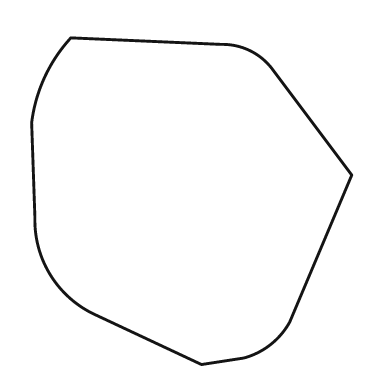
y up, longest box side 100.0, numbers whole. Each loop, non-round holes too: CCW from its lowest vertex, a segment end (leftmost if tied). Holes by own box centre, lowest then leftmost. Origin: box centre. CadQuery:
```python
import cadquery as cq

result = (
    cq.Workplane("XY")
    .moveTo(3.0, -50.0)
    .lineTo(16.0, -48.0)
    .threePointArc((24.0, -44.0), (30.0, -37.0))
    .lineTo(49.0, 8.0)
    .lineTo(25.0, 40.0)
    .threePointArc((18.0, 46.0), (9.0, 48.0))
    .lineTo(-37.0, 50.0)
    .threePointArc((-45.0, 38.0), (-49.0, 24.0))
    .lineTo(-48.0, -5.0)
    .threePointArc((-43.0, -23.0), (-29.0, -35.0))
    .close()
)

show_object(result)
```